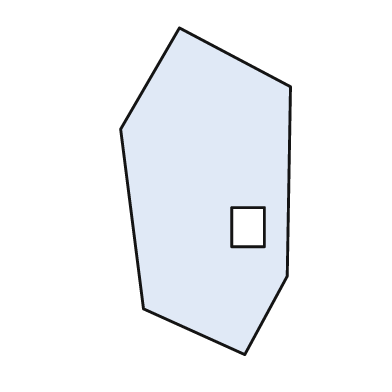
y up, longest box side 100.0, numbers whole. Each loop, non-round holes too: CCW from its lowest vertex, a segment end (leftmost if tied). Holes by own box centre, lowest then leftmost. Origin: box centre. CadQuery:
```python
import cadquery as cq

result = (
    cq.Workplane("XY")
    .moveTo(12.0, -50.0)
    .lineTo(25.0, -26.0)
    .lineTo(26.0, 32.0)
    .lineTo(-8.0, 50.0)
    .lineTo(-26.0, 19.0)
    .lineTo(-19.0, -36.0)
    .close()
    .moveTo(8.0, -17.0)
    .lineTo(18.0, -17.0)
    .lineTo(18.0, -5.0)
    .lineTo(8.0, -5.0)
    .close()
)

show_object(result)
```